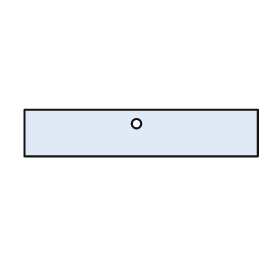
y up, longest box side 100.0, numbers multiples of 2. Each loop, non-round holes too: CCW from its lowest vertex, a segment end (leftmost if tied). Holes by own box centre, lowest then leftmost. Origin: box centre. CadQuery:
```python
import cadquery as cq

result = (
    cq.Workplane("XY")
    .moveTo(-50.0, -10.0)
    .lineTo(50.0, -10.0)
    .lineTo(50.0, 10.0)
    .lineTo(-50.0, 10.0)
    .close()
    .moveTo(-2.0, 4.0)
    .circle(2.0)
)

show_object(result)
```